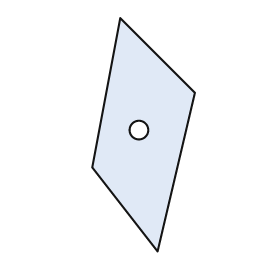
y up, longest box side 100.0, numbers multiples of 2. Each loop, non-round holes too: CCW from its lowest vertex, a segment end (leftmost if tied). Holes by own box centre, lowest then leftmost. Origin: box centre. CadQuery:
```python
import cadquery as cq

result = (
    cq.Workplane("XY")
    .moveTo(6.0, -50.0)
    .lineTo(22.0, 18.0)
    .lineTo(-10.0, 50.0)
    .lineTo(-22.0, -14.0)
    .close()
    .moveTo(-2.0, 2.0)
    .circle(4.0)
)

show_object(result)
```